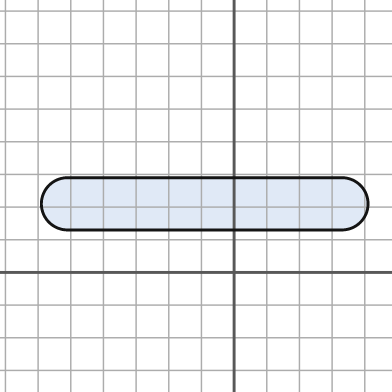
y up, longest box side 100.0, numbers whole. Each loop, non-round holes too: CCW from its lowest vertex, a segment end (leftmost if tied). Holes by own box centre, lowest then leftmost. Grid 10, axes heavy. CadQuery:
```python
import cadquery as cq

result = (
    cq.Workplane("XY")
    .moveTo(-51.0, 13.0)
    .lineTo(33.0, 13.0)
    .threePointArc((41.0, 21.0), (33.0, 29.0))
    .lineTo(-51.0, 29.0)
    .threePointArc((-59.0, 21.0), (-51.0, 13.0))
    .close()
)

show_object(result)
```